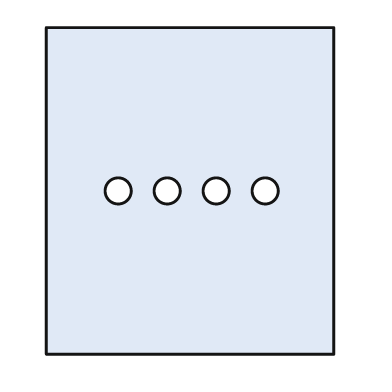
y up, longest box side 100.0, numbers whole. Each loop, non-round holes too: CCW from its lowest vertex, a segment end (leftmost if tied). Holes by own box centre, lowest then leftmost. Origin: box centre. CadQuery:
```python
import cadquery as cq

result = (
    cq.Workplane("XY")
    .moveTo(-44.0, -50.0)
    .lineTo(44.0, -50.0)
    .lineTo(44.0, 50.0)
    .lineTo(-44.0, 50.0)
    .close()
    .moveTo(-22.0, 0.0)
    .circle(4.0)
    .moveTo(-7.0, 0.0)
    .circle(4.0)
    .moveTo(8.0, 0.0)
    .circle(4.0)
    .moveTo(23.0, 0.0)
    .circle(4.0)
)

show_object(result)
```